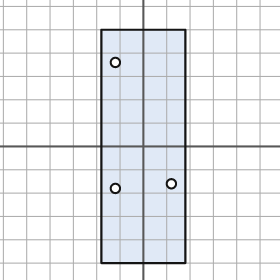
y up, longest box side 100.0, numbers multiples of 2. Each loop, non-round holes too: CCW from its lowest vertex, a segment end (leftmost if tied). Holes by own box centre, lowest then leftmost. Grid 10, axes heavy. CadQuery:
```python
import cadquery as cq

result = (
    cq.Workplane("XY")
    .moveTo(-18.0, -50.0)
    .lineTo(18.0, -50.0)
    .lineTo(18.0, 50.0)
    .lineTo(-18.0, 50.0)
    .close()
    .moveTo(-12.0, -18.0)
    .circle(2.0)
    .moveTo(12.0, -16.0)
    .circle(2.0)
    .moveTo(-12.0, 36.0)
    .circle(2.0)
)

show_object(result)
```